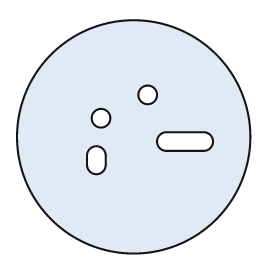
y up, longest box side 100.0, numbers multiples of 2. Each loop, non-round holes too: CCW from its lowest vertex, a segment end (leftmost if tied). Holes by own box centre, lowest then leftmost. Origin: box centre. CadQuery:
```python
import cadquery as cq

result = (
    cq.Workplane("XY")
    .moveTo(0.0, 0.0)
    .circle(50.0)
    .moveTo(-20.0, -12.0)
    .threePointArc((-16.0, -16.0), (-12.0, -12.0))
    .lineTo(-12.0, -8.0)
    .threePointArc((-16.0, -4.0), (-20.0, -8.0))
    .close()
    .moveTo(14.0, -6.0)
    .lineTo(30.0, -6.0)
    .threePointArc((34.0, -2.0), (30.0, 2.0))
    .lineTo(14.0, 2.0)
    .threePointArc((10.0, -2.0), (14.0, -6.0))
    .close()
    .moveTo(-14.0, 8.0)
    .circle(4.0)
    .moveTo(6.0, 18.0)
    .circle(4.0)
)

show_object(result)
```